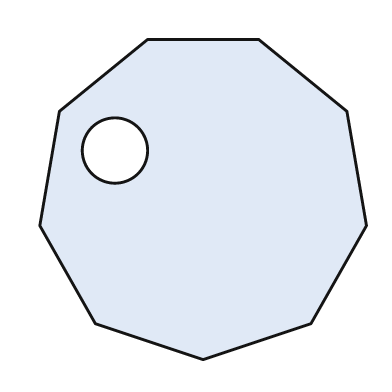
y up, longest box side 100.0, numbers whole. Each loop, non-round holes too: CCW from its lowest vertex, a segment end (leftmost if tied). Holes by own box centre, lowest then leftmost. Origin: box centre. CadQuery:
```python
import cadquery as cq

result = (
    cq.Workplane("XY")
    .moveTo(0.0, -49.0)
    .lineTo(33.0, -38.0)
    .lineTo(50.0, -8.0)
    .lineTo(44.0, 27.0)
    .lineTo(17.0, 49.0)
    .lineTo(-17.0, 49.0)
    .lineTo(-44.0, 27.0)
    .lineTo(-50.0, -8.0)
    .lineTo(-33.0, -38.0)
    .close()
    .moveTo(-27.0, 15.0)
    .circle(10.0)
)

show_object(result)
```